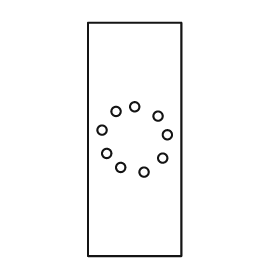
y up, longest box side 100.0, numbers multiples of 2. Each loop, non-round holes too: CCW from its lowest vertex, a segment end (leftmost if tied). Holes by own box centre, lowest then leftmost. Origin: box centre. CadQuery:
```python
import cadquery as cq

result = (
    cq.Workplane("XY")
    .moveTo(-20.0, -50.0)
    .lineTo(20.0, -50.0)
    .lineTo(20.0, 50.0)
    .lineTo(-20.0, 50.0)
    .close()
    .moveTo(4.0, -14.0)
    .circle(2.0)
    .moveTo(-6.0, -12.0)
    .circle(2.0)
    .moveTo(12.0, -8.0)
    .circle(2.0)
    .moveTo(-12.0, -6.0)
    .circle(2.0)
    .moveTo(14.0, 2.0)
    .circle(2.0)
    .moveTo(-14.0, 4.0)
    .circle(2.0)
    .moveTo(10.0, 10.0)
    .circle(2.0)
    .moveTo(-8.0, 12.0)
    .circle(2.0)
    .moveTo(0.0, 14.0)
    .circle(2.0)
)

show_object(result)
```